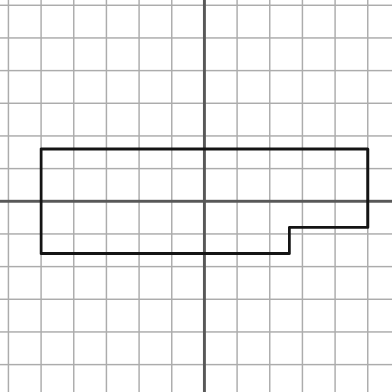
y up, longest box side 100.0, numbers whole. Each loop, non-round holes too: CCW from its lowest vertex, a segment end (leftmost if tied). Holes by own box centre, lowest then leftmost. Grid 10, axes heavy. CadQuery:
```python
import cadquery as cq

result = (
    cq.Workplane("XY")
    .moveTo(-50.0, -16.0)
    .lineTo(26.0, -16.0)
    .lineTo(26.0, -8.0)
    .lineTo(50.0, -8.0)
    .lineTo(50.0, 16.0)
    .lineTo(-50.0, 16.0)
    .close()
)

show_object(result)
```